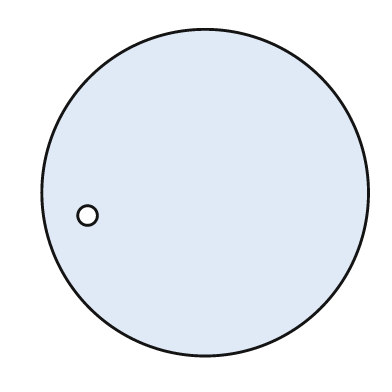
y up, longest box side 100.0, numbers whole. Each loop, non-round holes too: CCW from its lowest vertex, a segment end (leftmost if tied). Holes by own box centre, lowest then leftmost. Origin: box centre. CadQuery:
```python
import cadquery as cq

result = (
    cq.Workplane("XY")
    .moveTo(0.0, 0.0)
    .circle(50.0)
    .moveTo(-36.0, -7.0)
    .circle(3.0)
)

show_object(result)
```